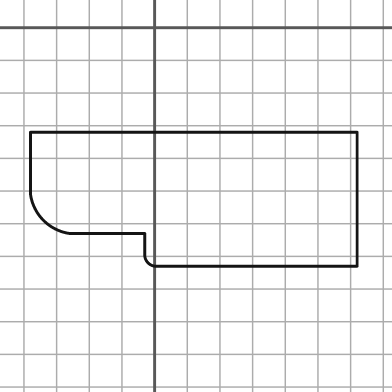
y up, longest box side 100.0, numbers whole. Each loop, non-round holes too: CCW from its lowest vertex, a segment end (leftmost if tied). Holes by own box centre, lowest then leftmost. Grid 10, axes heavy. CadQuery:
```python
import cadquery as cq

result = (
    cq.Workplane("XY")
    .moveTo(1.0, -73.0)
    .lineTo(62.0, -73.0)
    .lineTo(62.0, -32.0)
    .lineTo(-38.0, -32.0)
    .lineTo(-38.0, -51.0)
    .threePointArc((-34.0, -59.0), (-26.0, -63.0))
    .lineTo(-3.0, -63.0)
    .lineTo(-3.0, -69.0)
    .threePointArc((-2.0, -72.0), (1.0, -73.0))
    .close()
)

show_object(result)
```